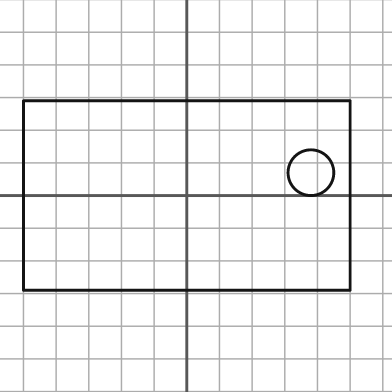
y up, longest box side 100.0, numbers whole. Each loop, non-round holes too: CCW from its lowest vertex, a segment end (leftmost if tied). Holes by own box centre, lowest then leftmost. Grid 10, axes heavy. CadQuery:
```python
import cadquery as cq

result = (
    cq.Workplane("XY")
    .moveTo(-50.0, -29.0)
    .lineTo(50.0, -29.0)
    .lineTo(50.0, 29.0)
    .lineTo(-50.0, 29.0)
    .close()
    .moveTo(38.0, 7.0)
    .circle(7.0)
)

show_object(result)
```